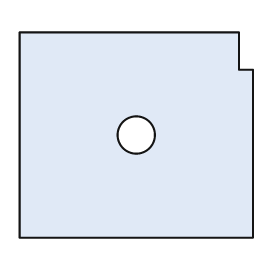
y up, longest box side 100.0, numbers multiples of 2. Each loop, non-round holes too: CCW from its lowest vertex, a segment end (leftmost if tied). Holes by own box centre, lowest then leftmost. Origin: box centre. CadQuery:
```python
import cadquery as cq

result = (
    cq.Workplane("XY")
    .moveTo(-50.0, -44.0)
    .lineTo(50.0, -44.0)
    .lineTo(50.0, 28.0)
    .lineTo(44.0, 28.0)
    .lineTo(44.0, 44.0)
    .lineTo(-50.0, 44.0)
    .close()
    .moveTo(0.0, 0.0)
    .circle(8.0)
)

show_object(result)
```